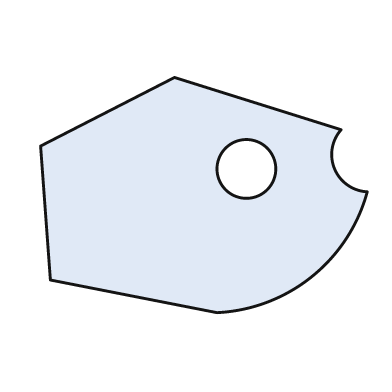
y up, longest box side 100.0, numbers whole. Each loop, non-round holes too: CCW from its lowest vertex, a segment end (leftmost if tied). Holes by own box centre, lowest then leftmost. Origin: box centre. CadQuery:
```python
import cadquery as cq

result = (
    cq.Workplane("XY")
    .moveTo(4.0, -36.0)
    .threePointArc((33.0, -25.0), (50.0, 1.0))
    .threePointArc((40.0, 8.0), (42.0, 20.0))
    .lineTo(-9.0, 36.0)
    .lineTo(-50.0, 15.0)
    .lineTo(-47.0, -26.0)
    .close()
    .moveTo(13.0, 8.0)
    .circle(9.0)
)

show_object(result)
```